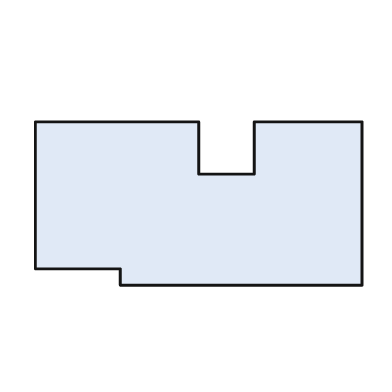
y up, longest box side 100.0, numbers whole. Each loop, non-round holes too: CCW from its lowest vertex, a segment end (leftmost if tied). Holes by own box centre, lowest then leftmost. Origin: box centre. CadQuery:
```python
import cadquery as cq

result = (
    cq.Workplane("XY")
    .moveTo(-24.0, -25.0)
    .lineTo(50.0, -25.0)
    .lineTo(50.0, 25.0)
    .lineTo(17.0, 25.0)
    .lineTo(17.0, 9.0)
    .lineTo(0.0, 9.0)
    .lineTo(0.0, 25.0)
    .lineTo(-50.0, 25.0)
    .lineTo(-50.0, -20.0)
    .lineTo(-24.0, -20.0)
    .close()
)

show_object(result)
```